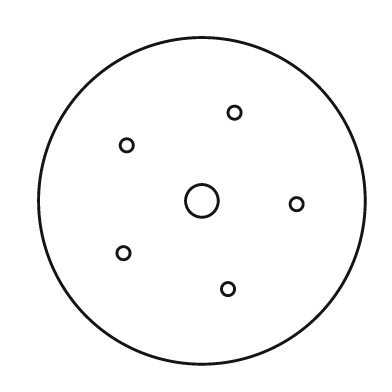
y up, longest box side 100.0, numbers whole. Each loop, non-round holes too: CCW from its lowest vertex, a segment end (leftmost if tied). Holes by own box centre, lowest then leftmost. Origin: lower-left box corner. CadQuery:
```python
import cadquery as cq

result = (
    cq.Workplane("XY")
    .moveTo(50.0, 50.0)
    .circle(50.0)
    .moveTo(58.0, 23.0)
    .circle(2.0)
    .moveTo(26.0, 34.0)
    .circle(2.0)
    .moveTo(79.0, 49.0)
    .circle(2.0)
    .moveTo(50.0, 50.0)
    .circle(5.0)
    .moveTo(27.0, 67.0)
    .circle(2.0)
    .moveTo(60.0, 77.0)
    .circle(2.0)
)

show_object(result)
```